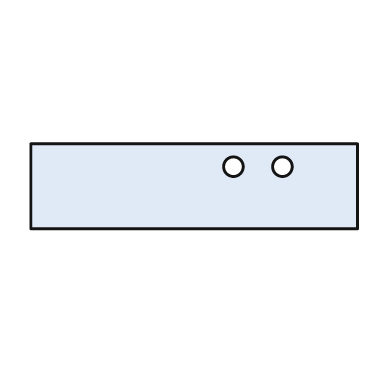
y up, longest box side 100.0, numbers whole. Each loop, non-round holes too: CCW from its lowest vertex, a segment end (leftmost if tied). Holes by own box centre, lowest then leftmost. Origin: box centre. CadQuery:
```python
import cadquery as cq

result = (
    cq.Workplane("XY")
    .moveTo(-50.0, -13.0)
    .lineTo(50.0, -13.0)
    .lineTo(50.0, 13.0)
    .lineTo(-50.0, 13.0)
    .close()
    .moveTo(12.0, 6.0)
    .circle(3.0)
    .moveTo(27.0, 6.0)
    .circle(3.0)
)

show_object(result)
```